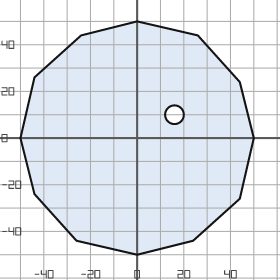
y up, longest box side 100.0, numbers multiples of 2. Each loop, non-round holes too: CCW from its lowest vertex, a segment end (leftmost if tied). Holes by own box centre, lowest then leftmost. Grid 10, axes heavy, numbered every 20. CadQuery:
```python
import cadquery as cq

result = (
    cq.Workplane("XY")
    .moveTo(0.0, -50.0)
    .lineTo(24.0, -44.0)
    .lineTo(44.0, -26.0)
    .lineTo(50.0, 0.0)
    .lineTo(44.0, 24.0)
    .lineTo(26.0, 44.0)
    .lineTo(0.0, 50.0)
    .lineTo(-24.0, 44.0)
    .lineTo(-44.0, 26.0)
    .lineTo(-50.0, 0.0)
    .lineTo(-44.0, -24.0)
    .lineTo(-26.0, -44.0)
    .close()
    .moveTo(16.0, 10.0)
    .circle(4.0)
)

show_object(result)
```